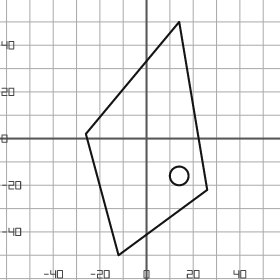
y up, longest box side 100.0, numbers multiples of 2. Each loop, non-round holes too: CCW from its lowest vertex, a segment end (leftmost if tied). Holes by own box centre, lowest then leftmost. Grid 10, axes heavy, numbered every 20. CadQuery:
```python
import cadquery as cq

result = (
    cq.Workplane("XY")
    .moveTo(-12.0, -50.0)
    .lineTo(26.0, -22.0)
    .lineTo(14.0, 50.0)
    .lineTo(-26.0, 2.0)
    .close()
    .moveTo(14.0, -16.0)
    .circle(4.0)
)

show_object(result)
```